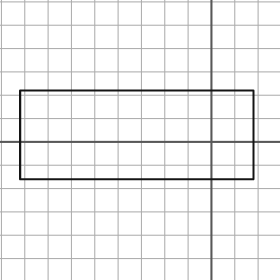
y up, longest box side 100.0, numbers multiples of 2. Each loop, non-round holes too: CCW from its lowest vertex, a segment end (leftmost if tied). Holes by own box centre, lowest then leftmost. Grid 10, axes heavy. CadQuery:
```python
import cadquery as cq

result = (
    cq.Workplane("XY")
    .moveTo(-82.0, -16.0)
    .lineTo(18.0, -16.0)
    .lineTo(18.0, 22.0)
    .lineTo(-82.0, 22.0)
    .close()
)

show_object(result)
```